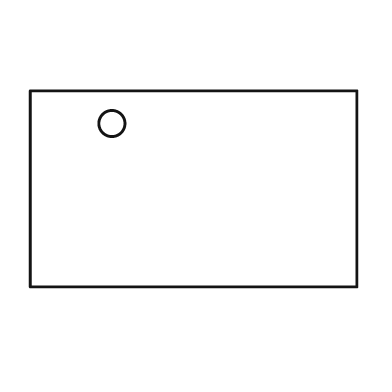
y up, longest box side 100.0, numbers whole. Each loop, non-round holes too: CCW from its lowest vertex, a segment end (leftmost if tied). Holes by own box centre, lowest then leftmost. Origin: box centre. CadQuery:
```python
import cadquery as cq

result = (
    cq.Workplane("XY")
    .moveTo(-50.0, -30.0)
    .lineTo(50.0, -30.0)
    .lineTo(50.0, 30.0)
    .lineTo(-50.0, 30.0)
    .close()
    .moveTo(-25.0, 20.0)
    .circle(4.0)
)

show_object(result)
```